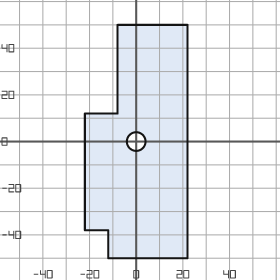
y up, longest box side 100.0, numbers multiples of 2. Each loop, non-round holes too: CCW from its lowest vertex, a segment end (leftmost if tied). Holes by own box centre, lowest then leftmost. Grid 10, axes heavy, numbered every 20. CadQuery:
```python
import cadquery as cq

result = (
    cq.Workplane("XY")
    .moveTo(-12.0, -50.0)
    .lineTo(22.0, -50.0)
    .lineTo(22.0, 50.0)
    .lineTo(-8.0, 50.0)
    .lineTo(-8.0, 12.0)
    .lineTo(-22.0, 12.0)
    .lineTo(-22.0, -38.0)
    .lineTo(-12.0, -38.0)
    .close()
    .moveTo(0.0, 0.0)
    .circle(4.0)
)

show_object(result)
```